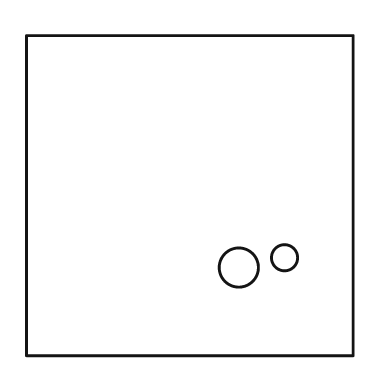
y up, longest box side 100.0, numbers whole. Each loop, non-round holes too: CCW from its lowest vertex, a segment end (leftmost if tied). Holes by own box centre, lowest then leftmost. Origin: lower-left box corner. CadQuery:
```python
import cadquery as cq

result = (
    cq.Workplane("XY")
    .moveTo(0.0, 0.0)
    .lineTo(100.0, 0.0)
    .lineTo(100.0, 98.0)
    .lineTo(0.0, 98.0)
    .close()
    .moveTo(65.0, 27.0)
    .circle(6.0)
    .moveTo(79.0, 30.0)
    .circle(4.0)
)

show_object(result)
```